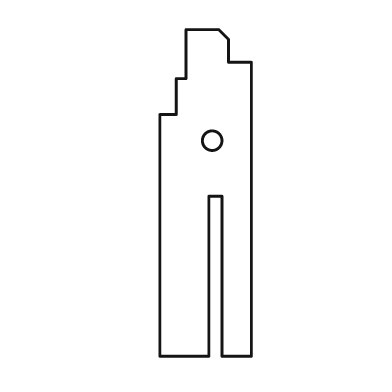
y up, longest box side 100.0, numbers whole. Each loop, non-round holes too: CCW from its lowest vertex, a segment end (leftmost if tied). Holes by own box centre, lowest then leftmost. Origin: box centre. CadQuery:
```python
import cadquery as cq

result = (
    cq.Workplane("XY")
    .moveTo(-14.0, -50.0)
    .lineTo(1.0, -50.0)
    .lineTo(1.0, -1.0)
    .lineTo(5.0, -1.0)
    .lineTo(5.0, -50.0)
    .lineTo(14.0, -50.0)
    .lineTo(14.0, 40.0)
    .lineTo(7.0, 40.0)
    .lineTo(7.0, 47.0)
    .lineTo(4.0, 50.0)
    .lineTo(-6.0, 50.0)
    .lineTo(-6.0, 35.0)
    .lineTo(-9.0, 35.0)
    .lineTo(-9.0, 24.0)
    .lineTo(-14.0, 24.0)
    .close()
    .moveTo(2.0, 16.0)
    .circle(3.0)
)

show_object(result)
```